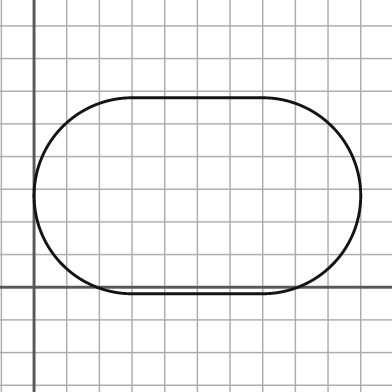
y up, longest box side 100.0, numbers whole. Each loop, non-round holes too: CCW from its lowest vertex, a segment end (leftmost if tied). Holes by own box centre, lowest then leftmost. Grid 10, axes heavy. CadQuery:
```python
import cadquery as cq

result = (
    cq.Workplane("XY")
    .moveTo(30.0, -2.0)
    .lineTo(70.0, -2.0)
    .threePointArc((100.0, 28.0), (70.0, 58.0))
    .lineTo(30.0, 58.0)
    .threePointArc((0.0, 28.0), (30.0, -2.0))
    .close()
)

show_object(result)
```